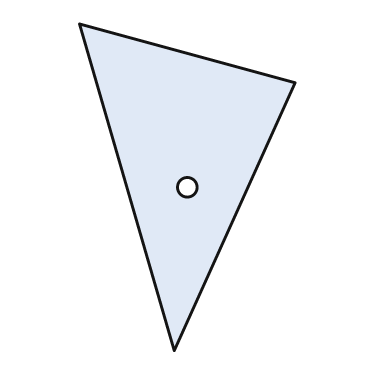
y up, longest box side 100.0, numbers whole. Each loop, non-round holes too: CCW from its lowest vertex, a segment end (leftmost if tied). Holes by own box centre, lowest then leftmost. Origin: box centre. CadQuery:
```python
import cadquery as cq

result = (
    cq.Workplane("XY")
    .moveTo(-4.0, -50.0)
    .lineTo(33.0, 32.0)
    .lineTo(-33.0, 50.0)
    .close()
    .moveTo(0.0, 0.0)
    .circle(3.0)
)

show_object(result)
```